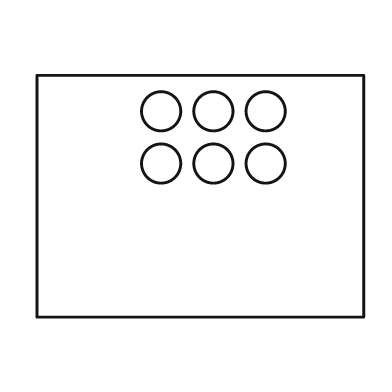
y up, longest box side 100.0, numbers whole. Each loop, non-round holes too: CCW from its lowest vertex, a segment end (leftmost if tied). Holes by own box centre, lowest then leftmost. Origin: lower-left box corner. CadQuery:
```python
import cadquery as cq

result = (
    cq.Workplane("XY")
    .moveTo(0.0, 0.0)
    .lineTo(100.0, 0.0)
    .lineTo(100.0, 74.0)
    .lineTo(0.0, 74.0)
    .close()
    .moveTo(38.0, 47.0)
    .circle(6.0)
    .moveTo(54.0, 47.0)
    .circle(6.0)
    .moveTo(70.0, 47.0)
    .circle(6.0)
    .moveTo(38.0, 63.0)
    .circle(6.0)
    .moveTo(54.0, 63.0)
    .circle(6.0)
    .moveTo(70.0, 63.0)
    .circle(6.0)
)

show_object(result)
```